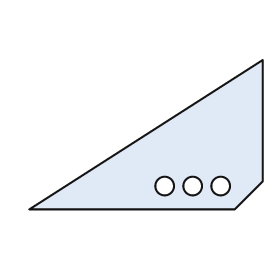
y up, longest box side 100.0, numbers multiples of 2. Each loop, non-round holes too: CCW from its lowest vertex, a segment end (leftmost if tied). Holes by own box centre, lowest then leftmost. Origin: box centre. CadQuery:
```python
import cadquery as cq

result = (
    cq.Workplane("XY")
    .moveTo(-50.0, -32.0)
    .lineTo(38.0, -32.0)
    .lineTo(50.0, -20.0)
    .lineTo(50.0, 32.0)
    .close()
    .moveTo(8.0, -22.0)
    .circle(4.0)
    .moveTo(20.0, -22.0)
    .circle(4.0)
    .moveTo(32.0, -22.0)
    .circle(4.0)
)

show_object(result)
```